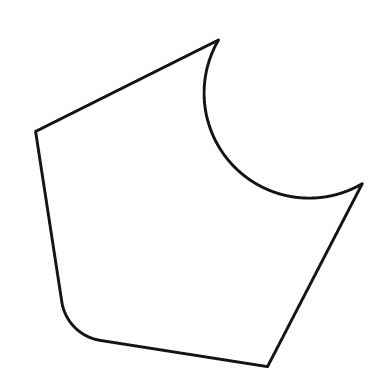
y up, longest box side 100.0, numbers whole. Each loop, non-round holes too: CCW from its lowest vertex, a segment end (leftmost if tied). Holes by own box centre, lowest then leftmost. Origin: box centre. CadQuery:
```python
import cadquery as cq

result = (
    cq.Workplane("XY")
    .moveTo(21.0, -50.0)
    .lineTo(50.0, 6.0)
    .threePointArc((11.0, 11.0), (6.0, 50.0))
    .lineTo(-50.0, 22.0)
    .lineTo(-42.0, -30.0)
    .threePointArc((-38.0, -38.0), (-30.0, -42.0))
    .close()
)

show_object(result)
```